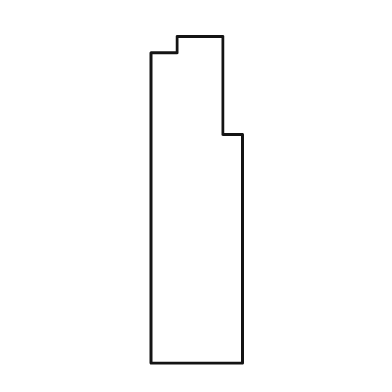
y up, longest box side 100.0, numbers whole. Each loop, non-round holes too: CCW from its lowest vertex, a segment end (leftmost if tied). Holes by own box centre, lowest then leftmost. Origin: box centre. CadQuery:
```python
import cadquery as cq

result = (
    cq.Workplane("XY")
    .moveTo(-14.0, -50.0)
    .lineTo(14.0, -50.0)
    .lineTo(14.0, 20.0)
    .lineTo(8.0, 20.0)
    .lineTo(8.0, 50.0)
    .lineTo(-6.0, 50.0)
    .lineTo(-6.0, 45.0)
    .lineTo(-14.0, 45.0)
    .close()
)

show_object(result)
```